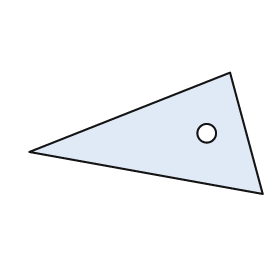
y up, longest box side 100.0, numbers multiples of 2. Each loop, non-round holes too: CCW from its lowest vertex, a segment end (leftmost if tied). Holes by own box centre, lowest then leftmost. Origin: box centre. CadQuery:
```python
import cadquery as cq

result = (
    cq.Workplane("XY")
    .moveTo(50.0, -26.0)
    .lineTo(36.0, 26.0)
    .lineTo(-50.0, -8.0)
    .close()
    .moveTo(26.0, 0.0)
    .circle(4.0)
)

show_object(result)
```